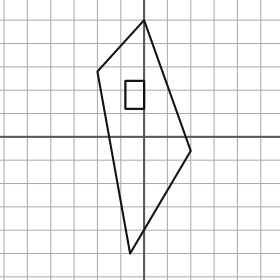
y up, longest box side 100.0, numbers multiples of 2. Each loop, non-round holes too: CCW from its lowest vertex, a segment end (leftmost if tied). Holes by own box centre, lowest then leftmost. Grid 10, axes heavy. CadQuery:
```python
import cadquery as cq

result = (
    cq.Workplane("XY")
    .moveTo(-6.0, -50.0)
    .lineTo(20.0, -6.0)
    .lineTo(0.0, 50.0)
    .lineTo(-20.0, 28.0)
    .close()
    .moveTo(-8.0, 12.0)
    .lineTo(0.0, 12.0)
    .lineTo(0.0, 24.0)
    .lineTo(-8.0, 24.0)
    .close()
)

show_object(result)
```